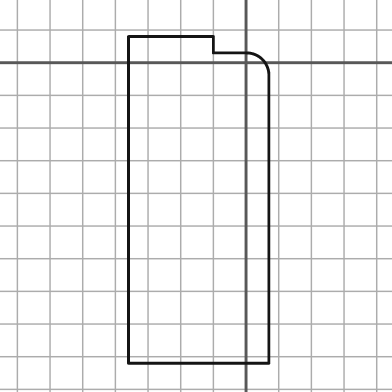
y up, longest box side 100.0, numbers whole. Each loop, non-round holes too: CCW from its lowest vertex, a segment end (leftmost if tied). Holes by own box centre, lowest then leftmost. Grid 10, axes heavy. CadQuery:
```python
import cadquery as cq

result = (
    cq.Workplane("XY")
    .moveTo(-36.0, -92.0)
    .lineTo(7.0, -92.0)
    .lineTo(7.0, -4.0)
    .threePointArc((5.0, 1.0), (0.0, 3.0))
    .lineTo(-10.0, 3.0)
    .lineTo(-10.0, 8.0)
    .lineTo(-36.0, 8.0)
    .close()
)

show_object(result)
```